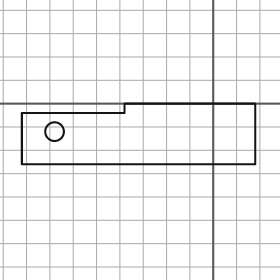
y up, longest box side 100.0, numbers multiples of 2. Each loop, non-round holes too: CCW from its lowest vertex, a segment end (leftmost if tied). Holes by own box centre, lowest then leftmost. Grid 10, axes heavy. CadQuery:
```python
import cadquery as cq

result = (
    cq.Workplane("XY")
    .moveTo(-82.0, -26.0)
    .lineTo(18.0, -26.0)
    .lineTo(18.0, 0.0)
    .lineTo(-38.0, 0.0)
    .lineTo(-38.0, -4.0)
    .lineTo(-82.0, -4.0)
    .close()
    .moveTo(-68.0, -12.0)
    .circle(4.0)
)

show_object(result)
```